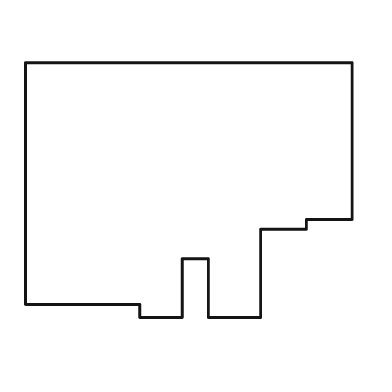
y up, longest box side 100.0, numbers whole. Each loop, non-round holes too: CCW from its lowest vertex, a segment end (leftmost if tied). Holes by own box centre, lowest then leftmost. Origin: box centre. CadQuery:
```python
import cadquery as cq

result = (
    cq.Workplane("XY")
    .moveTo(-15.0, -39.0)
    .lineTo(-2.0, -39.0)
    .lineTo(-2.0, -21.0)
    .lineTo(6.0, -21.0)
    .lineTo(6.0, -39.0)
    .lineTo(22.0, -39.0)
    .lineTo(22.0, -12.0)
    .lineTo(36.0, -12.0)
    .lineTo(36.0, -9.0)
    .lineTo(50.0, -9.0)
    .lineTo(50.0, 39.0)
    .lineTo(-50.0, 39.0)
    .lineTo(-50.0, -35.0)
    .lineTo(-15.0, -35.0)
    .close()
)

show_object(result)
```